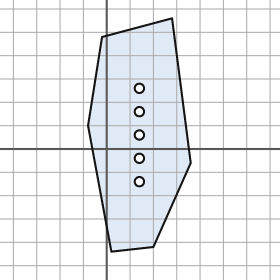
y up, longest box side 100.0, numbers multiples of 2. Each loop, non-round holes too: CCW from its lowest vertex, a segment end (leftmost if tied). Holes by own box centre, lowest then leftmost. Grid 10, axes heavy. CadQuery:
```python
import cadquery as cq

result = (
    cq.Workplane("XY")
    .moveTo(2.0, -44.0)
    .lineTo(20.0, -42.0)
    .lineTo(36.0, -6.0)
    .lineTo(28.0, 56.0)
    .lineTo(-2.0, 48.0)
    .lineTo(-8.0, 10.0)
    .close()
    .moveTo(14.0, -14.0)
    .circle(2.0)
    .moveTo(14.0, -4.0)
    .circle(2.0)
    .moveTo(14.0, 6.0)
    .circle(2.0)
    .moveTo(14.0, 16.0)
    .circle(2.0)
    .moveTo(14.0, 26.0)
    .circle(2.0)
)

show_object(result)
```